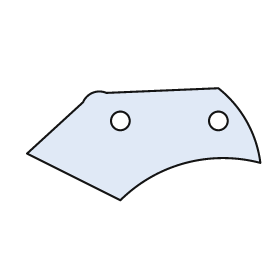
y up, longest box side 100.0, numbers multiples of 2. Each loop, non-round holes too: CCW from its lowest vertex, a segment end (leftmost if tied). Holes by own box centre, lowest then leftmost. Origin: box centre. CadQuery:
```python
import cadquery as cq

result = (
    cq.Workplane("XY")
    .moveTo(-10.0, -24.0)
    .threePointArc((18.0, -8.0), (50.0, -8.0))
    .threePointArc((44.0, 10.0), (32.0, 24.0))
    .lineTo(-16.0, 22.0)
    .threePointArc((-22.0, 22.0), (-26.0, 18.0))
    .lineTo(-50.0, -4.0)
    .close()
    .moveTo(-10.0, 10.0)
    .circle(4.0)
    .moveTo(32.0, 10.0)
    .circle(4.0)
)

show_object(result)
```